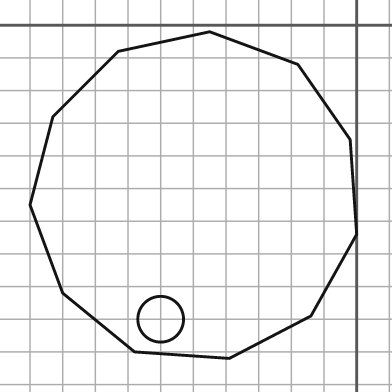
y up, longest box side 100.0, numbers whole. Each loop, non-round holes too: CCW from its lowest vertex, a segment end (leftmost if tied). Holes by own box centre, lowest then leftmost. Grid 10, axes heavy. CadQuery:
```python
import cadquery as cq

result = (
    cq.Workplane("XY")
    .moveTo(-39.0, -102.0)
    .lineTo(-14.0, -89.0)
    .lineTo(0.0, -64.0)
    .lineTo(-2.0, -35.0)
    .lineTo(-18.0, -12.0)
    .lineTo(-45.0, -2.0)
    .lineTo(-73.0, -8.0)
    .lineTo(-93.0, -28.0)
    .lineTo(-100.0, -55.0)
    .lineTo(-90.0, -82.0)
    .lineTo(-68.0, -100.0)
    .close()
    .moveTo(-60.0, -90.0)
    .circle(7.0)
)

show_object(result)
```